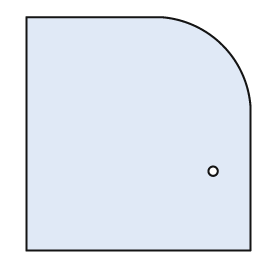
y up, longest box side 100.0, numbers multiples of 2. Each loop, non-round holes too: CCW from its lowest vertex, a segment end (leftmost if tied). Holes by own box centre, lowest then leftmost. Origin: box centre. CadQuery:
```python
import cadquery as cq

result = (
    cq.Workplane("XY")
    .moveTo(-48.0, -50.0)
    .lineTo(48.0, -50.0)
    .lineTo(48.0, 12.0)
    .threePointArc((36.0, 38.0), (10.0, 50.0))
    .lineTo(-48.0, 50.0)
    .close()
    .moveTo(32.0, -16.0)
    .circle(2.0)
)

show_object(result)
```